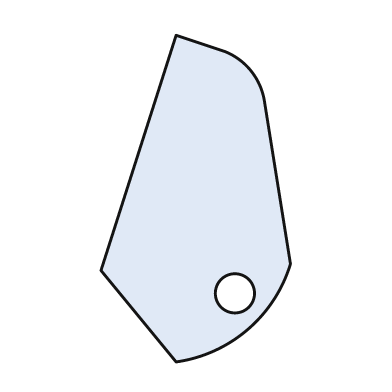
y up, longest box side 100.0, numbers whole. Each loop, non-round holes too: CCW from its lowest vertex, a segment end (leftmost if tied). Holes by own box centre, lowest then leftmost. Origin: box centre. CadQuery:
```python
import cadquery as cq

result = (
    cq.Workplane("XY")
    .moveTo(-6.0, -50.0)
    .threePointArc((16.0, -40.0), (29.0, -20.0))
    .lineTo(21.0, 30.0)
    .threePointArc((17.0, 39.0), (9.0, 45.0))
    .lineTo(-6.0, 50.0)
    .lineTo(-29.0, -22.0)
    .close()
    .moveTo(12.0, -29.0)
    .circle(6.0)
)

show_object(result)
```